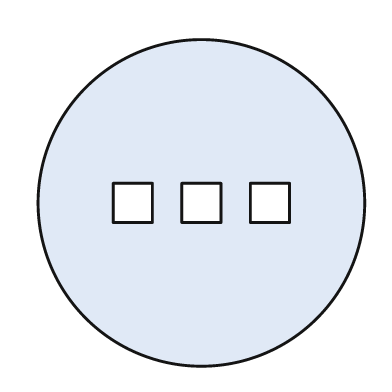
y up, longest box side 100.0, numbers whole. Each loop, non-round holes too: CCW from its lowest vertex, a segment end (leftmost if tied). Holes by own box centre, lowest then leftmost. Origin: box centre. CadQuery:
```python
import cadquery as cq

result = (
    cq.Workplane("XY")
    .moveTo(0.0, 0.0)
    .circle(50.0)
    .moveTo(-27.0, -6.0)
    .lineTo(-15.0, -6.0)
    .lineTo(-15.0, 6.0)
    .lineTo(-27.0, 6.0)
    .close()
    .moveTo(-6.0, -6.0)
    .lineTo(6.0, -6.0)
    .lineTo(6.0, 6.0)
    .lineTo(-6.0, 6.0)
    .close()
    .moveTo(15.0, -6.0)
    .lineTo(27.0, -6.0)
    .lineTo(27.0, 6.0)
    .lineTo(15.0, 6.0)
    .close()
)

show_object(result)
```